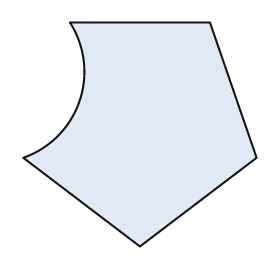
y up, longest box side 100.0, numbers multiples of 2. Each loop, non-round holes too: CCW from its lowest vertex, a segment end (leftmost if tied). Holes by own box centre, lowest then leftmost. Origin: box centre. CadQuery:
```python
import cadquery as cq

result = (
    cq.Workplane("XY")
    .moveTo(0.0, -48.0)
    .lineTo(50.0, -10.0)
    .lineTo(30.0, 48.0)
    .lineTo(-30.0, 48.0)
    .threePointArc((-26.0, 14.0), (-50.0, -10.0))
    .close()
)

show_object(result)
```